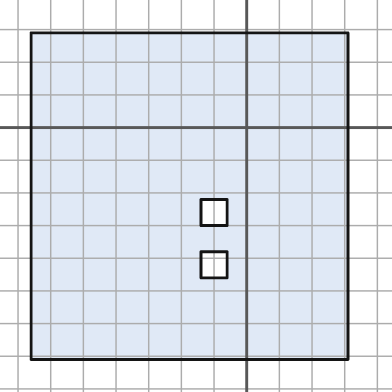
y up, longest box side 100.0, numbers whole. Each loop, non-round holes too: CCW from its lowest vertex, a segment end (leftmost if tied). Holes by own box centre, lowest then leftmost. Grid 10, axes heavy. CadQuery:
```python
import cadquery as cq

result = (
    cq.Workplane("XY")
    .moveTo(-66.0, -71.0)
    .lineTo(31.0, -71.0)
    .lineTo(31.0, 29.0)
    .lineTo(-66.0, 29.0)
    .close()
    .moveTo(-14.0, -46.0)
    .lineTo(-6.0, -46.0)
    .lineTo(-6.0, -38.0)
    .lineTo(-14.0, -38.0)
    .close()
    .moveTo(-14.0, -30.0)
    .lineTo(-6.0, -30.0)
    .lineTo(-6.0, -22.0)
    .lineTo(-14.0, -22.0)
    .close()
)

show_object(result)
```